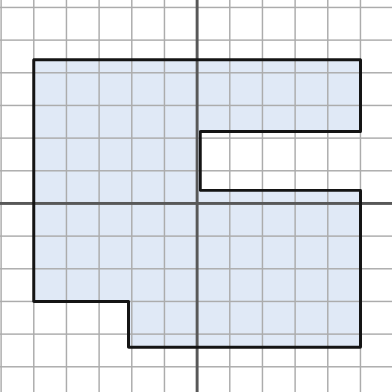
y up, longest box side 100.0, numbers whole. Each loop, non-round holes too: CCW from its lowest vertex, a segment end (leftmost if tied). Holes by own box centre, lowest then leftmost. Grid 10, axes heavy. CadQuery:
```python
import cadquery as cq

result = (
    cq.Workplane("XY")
    .moveTo(-21.0, -44.0)
    .lineTo(50.0, -44.0)
    .lineTo(50.0, 4.0)
    .lineTo(1.0, 4.0)
    .lineTo(1.0, 22.0)
    .lineTo(50.0, 22.0)
    .lineTo(50.0, 44.0)
    .lineTo(-50.0, 44.0)
    .lineTo(-50.0, -30.0)
    .lineTo(-21.0, -30.0)
    .close()
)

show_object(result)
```